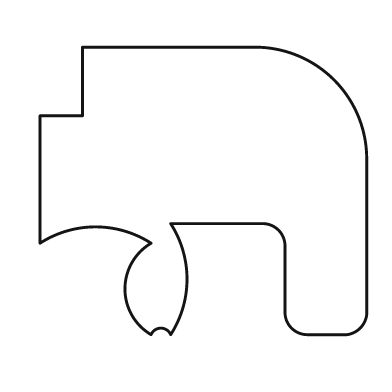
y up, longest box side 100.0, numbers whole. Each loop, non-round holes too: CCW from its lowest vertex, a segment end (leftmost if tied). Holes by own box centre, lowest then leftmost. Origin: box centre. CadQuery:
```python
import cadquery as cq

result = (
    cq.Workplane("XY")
    .moveTo(-16.0, -44.0)
    .threePointArc((-13.0, -42.0), (-10.0, -44.0))
    .threePointArc((-5.0, -27.0), (-10.0, -10.0))
    .lineTo(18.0, -10.0)
    .threePointArc((23.0, -12.0), (25.0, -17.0))
    .lineTo(25.0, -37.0)
    .threePointArc((27.0, -42.0), (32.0, -44.0))
    .lineTo(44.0, -44.0)
    .threePointArc((48.0, -42.0), (50.0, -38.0))
    .lineTo(50.0, 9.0)
    .threePointArc((40.0, 34.0), (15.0, 44.0))
    .lineTo(-37.0, 44.0)
    .lineTo(-37.0, 23.0)
    .lineTo(-50.0, 23.0)
    .lineTo(-50.0, -16.0)
    .threePointArc((-33.0, -11.0), (-16.0, -16.0))
    .threePointArc((-24.0, -30.0), (-16.0, -44.0))
    .close()
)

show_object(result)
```